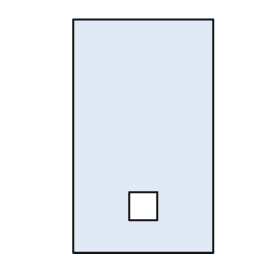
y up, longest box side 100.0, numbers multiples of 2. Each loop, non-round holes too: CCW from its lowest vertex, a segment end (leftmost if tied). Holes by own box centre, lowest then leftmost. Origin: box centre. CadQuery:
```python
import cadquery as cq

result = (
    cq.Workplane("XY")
    .moveTo(-30.0, -50.0)
    .lineTo(30.0, -50.0)
    .lineTo(30.0, 50.0)
    .lineTo(-30.0, 50.0)
    .close()
    .moveTo(-6.0, -36.0)
    .lineTo(6.0, -36.0)
    .lineTo(6.0, -24.0)
    .lineTo(-6.0, -24.0)
    .close()
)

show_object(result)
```